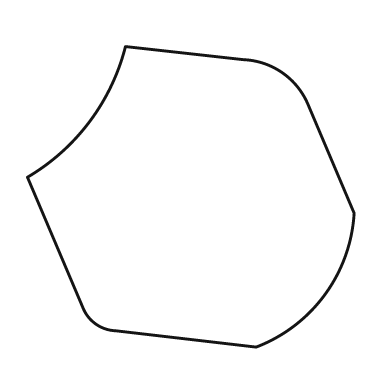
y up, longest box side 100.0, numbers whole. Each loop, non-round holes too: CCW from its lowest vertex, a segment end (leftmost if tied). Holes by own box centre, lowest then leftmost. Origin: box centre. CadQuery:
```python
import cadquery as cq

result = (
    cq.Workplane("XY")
    .moveTo(20.0, -46.0)
    .threePointArc((41.0, -30.0), (50.0, -5.0))
    .lineTo(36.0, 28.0)
    .threePointArc((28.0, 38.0), (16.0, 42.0))
    .lineTo(-20.0, 46.0)
    .threePointArc((-31.0, 23.0), (-50.0, 6.0))
    .lineTo(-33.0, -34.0)
    .threePointArc((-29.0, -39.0), (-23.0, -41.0))
    .close()
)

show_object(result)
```